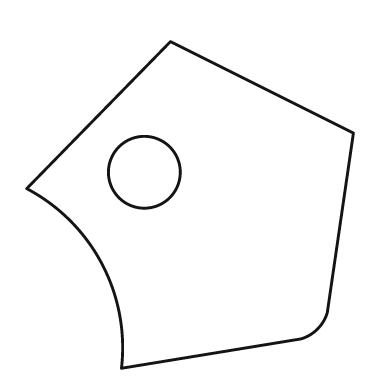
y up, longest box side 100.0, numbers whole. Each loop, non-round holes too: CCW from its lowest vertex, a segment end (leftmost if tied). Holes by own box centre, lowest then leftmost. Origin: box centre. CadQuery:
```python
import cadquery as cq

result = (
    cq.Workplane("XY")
    .moveTo(-21.0, -50.0)
    .lineTo(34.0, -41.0)
    .threePointArc((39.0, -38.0), (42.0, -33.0))
    .lineTo(50.0, 22.0)
    .lineTo(-6.0, 50.0)
    .lineTo(-50.0, 5.0)
    .threePointArc((-27.0, -18.0), (-21.0, -50.0))
    .close()
    .moveTo(-14.0, 10.0)
    .circle(11.0)
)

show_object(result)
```